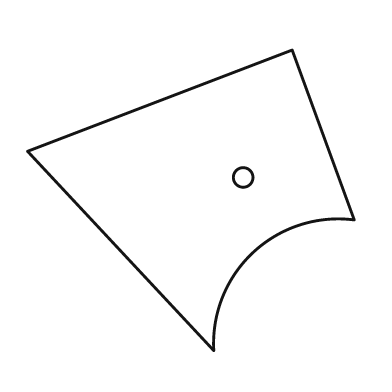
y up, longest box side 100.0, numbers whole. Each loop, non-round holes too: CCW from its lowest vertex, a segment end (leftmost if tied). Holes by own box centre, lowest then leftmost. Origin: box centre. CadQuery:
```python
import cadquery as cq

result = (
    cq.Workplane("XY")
    .moveTo(7.0, -46.0)
    .threePointArc((19.0, -16.0), (50.0, -6.0))
    .lineTo(31.0, 46.0)
    .lineTo(-50.0, 15.0)
    .close()
    .moveTo(16.0, 7.0)
    .circle(3.0)
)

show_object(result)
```